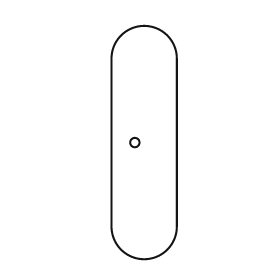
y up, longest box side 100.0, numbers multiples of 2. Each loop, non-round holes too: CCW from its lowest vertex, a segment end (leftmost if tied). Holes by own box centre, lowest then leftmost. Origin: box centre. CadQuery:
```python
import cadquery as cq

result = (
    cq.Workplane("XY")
    .moveTo(-14.0, -36.0)
    .threePointArc((0.0, -50.0), (14.0, -36.0))
    .lineTo(14.0, 36.0)
    .threePointArc((0.0, 50.0), (-14.0, 36.0))
    .close()
    .moveTo(-4.0, 0.0)
    .circle(2.0)
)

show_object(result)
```